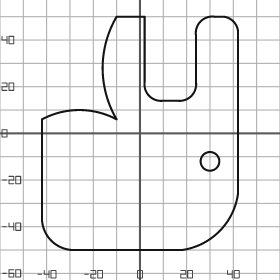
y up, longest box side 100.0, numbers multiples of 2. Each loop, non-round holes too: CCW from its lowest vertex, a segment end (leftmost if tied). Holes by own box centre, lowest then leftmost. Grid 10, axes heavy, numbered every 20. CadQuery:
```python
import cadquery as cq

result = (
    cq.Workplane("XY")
    .moveTo(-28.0, -50.0)
    .lineTo(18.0, -50.0)
    .threePointArc((34.0, -42.0), (42.0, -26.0))
    .lineTo(42.0, 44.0)
    .threePointArc((40.0, 48.0), (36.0, 50.0))
    .lineTo(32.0, 50.0)
    .threePointArc((26.0, 48.0), (24.0, 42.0))
    .lineTo(24.0, 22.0)
    .threePointArc((22.0, 16.0), (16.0, 14.0))
    .lineTo(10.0, 14.0)
    .threePointArc((4.0, 16.0), (2.0, 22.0))
    .lineTo(2.0, 50.0)
    .lineTo(-10.0, 50.0)
    .threePointArc((-16.0, 28.0), (-10.0, 6.0))
    .threePointArc((-26.0, 10.0), (-42.0, 6.0))
    .lineTo(-42.0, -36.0)
    .threePointArc((-38.0, -46.0), (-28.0, -50.0))
    .close()
    .moveTo(30.0, -12.0)
    .circle(4.0)
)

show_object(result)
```